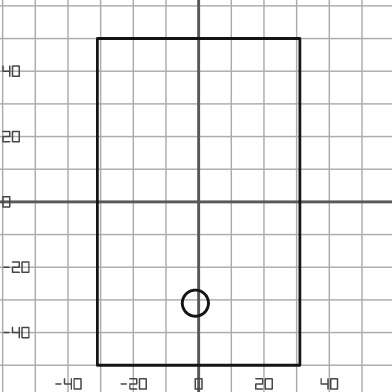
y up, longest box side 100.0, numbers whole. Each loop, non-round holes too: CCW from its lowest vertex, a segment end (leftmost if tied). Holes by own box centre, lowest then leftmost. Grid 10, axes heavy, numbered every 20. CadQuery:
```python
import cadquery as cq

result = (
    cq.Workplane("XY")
    .moveTo(-31.0, -50.0)
    .lineTo(31.0, -50.0)
    .lineTo(31.0, 50.0)
    .lineTo(-31.0, 50.0)
    .close()
    .moveTo(-1.0, -31.0)
    .circle(4.0)
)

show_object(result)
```